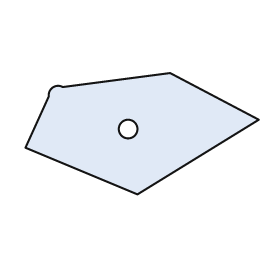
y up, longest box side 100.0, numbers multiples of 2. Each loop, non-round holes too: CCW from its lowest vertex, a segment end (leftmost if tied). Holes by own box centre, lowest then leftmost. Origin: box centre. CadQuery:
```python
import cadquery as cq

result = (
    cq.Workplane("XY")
    .moveTo(-2.0, -26.0)
    .lineTo(50.0, 6.0)
    .lineTo(12.0, 26.0)
    .lineTo(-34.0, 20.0)
    .threePointArc((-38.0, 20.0), (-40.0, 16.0))
    .lineTo(-50.0, -6.0)
    .close()
    .moveTo(-6.0, 2.0)
    .circle(4.0)
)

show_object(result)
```